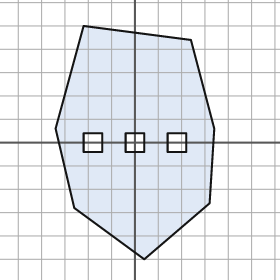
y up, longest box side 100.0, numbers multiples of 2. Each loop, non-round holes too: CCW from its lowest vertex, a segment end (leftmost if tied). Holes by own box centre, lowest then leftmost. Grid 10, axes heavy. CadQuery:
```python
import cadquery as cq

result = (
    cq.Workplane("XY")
    .moveTo(4.0, -50.0)
    .lineTo(32.0, -26.0)
    .lineTo(34.0, 6.0)
    .lineTo(24.0, 44.0)
    .lineTo(-22.0, 50.0)
    .lineTo(-34.0, 6.0)
    .lineTo(-26.0, -28.0)
    .close()
    .moveTo(-22.0, -4.0)
    .lineTo(-14.0, -4.0)
    .lineTo(-14.0, 4.0)
    .lineTo(-22.0, 4.0)
    .close()
    .moveTo(-4.0, -4.0)
    .lineTo(4.0, -4.0)
    .lineTo(4.0, 4.0)
    .lineTo(-4.0, 4.0)
    .close()
    .moveTo(14.0, -4.0)
    .lineTo(22.0, -4.0)
    .lineTo(22.0, 4.0)
    .lineTo(14.0, 4.0)
    .close()
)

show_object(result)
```